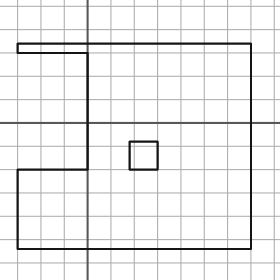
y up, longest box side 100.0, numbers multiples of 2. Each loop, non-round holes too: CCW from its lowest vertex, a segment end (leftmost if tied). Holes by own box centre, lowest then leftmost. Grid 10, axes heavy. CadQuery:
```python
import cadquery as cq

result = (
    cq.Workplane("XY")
    .moveTo(-30.0, -54.0)
    .lineTo(70.0, -54.0)
    .lineTo(70.0, 34.0)
    .lineTo(-30.0, 34.0)
    .lineTo(-30.0, 30.0)
    .lineTo(0.0, 30.0)
    .lineTo(0.0, -20.0)
    .lineTo(-30.0, -20.0)
    .close()
    .moveTo(18.0, -20.0)
    .lineTo(30.0, -20.0)
    .lineTo(30.0, -8.0)
    .lineTo(18.0, -8.0)
    .close()
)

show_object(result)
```